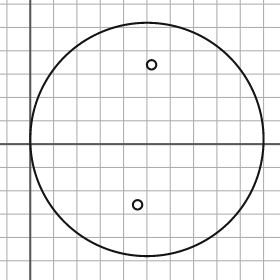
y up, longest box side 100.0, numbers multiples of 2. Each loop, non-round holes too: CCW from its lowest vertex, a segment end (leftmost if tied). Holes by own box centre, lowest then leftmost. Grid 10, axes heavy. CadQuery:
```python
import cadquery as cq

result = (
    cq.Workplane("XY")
    .moveTo(50.0, 2.0)
    .circle(50.0)
    .moveTo(46.0, -26.0)
    .circle(2.0)
    .moveTo(52.0, 34.0)
    .circle(2.0)
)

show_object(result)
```